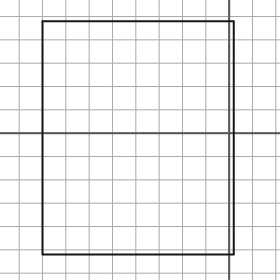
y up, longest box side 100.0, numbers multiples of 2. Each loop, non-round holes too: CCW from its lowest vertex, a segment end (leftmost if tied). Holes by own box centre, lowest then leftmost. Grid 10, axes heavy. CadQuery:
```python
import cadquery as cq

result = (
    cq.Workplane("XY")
    .moveTo(-80.0, -52.0)
    .lineTo(2.0, -52.0)
    .lineTo(2.0, 48.0)
    .lineTo(-80.0, 48.0)
    .close()
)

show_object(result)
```